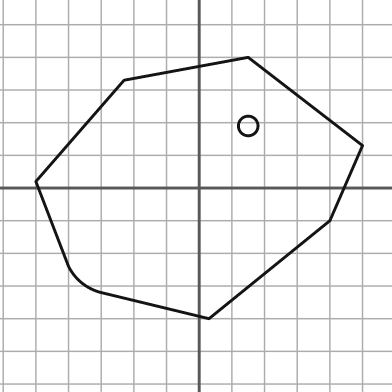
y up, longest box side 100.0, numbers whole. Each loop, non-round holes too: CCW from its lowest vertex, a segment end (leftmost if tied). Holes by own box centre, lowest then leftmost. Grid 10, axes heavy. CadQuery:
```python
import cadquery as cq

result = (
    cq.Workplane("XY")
    .moveTo(3.0, -40.0)
    .lineTo(40.0, -10.0)
    .lineTo(50.0, 13.0)
    .lineTo(15.0, 40.0)
    .lineTo(-23.0, 33.0)
    .lineTo(-50.0, 2.0)
    .lineTo(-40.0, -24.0)
    .threePointArc((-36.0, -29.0), (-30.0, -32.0))
    .close()
    .moveTo(15.0, 19.0)
    .circle(3.0)
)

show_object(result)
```